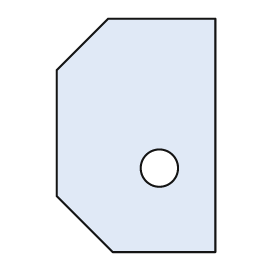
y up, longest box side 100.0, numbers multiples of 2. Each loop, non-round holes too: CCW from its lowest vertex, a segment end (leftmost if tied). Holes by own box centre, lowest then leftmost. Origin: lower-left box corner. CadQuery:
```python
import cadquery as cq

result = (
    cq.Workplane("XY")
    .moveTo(24.0, 0.0)
    .lineTo(68.0, 0.0)
    .lineTo(68.0, 100.0)
    .lineTo(22.0, 100.0)
    .lineTo(0.0, 78.0)
    .lineTo(0.0, 24.0)
    .close()
    .moveTo(44.0, 36.0)
    .circle(8.0)
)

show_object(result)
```